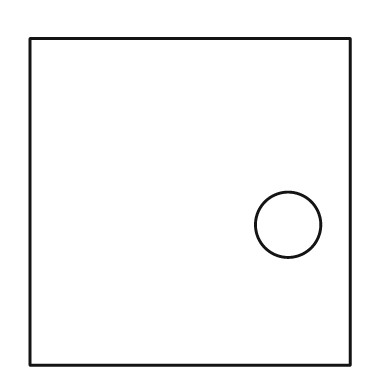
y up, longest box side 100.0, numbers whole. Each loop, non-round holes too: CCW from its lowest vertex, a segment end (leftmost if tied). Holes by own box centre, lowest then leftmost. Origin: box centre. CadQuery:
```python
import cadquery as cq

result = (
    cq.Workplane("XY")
    .moveTo(-49.0, -50.0)
    .lineTo(49.0, -50.0)
    .lineTo(49.0, 50.0)
    .lineTo(-49.0, 50.0)
    .close()
    .moveTo(30.0, -7.0)
    .circle(10.0)
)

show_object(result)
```